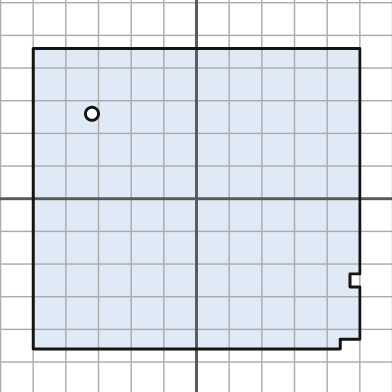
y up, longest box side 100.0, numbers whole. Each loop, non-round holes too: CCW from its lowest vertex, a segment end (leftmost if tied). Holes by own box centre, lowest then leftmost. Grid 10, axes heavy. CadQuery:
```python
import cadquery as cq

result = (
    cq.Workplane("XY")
    .moveTo(-50.0, -46.0)
    .lineTo(44.0, -46.0)
    .lineTo(44.0, -43.0)
    .lineTo(50.0, -43.0)
    .lineTo(50.0, -27.0)
    .lineTo(47.0, -27.0)
    .lineTo(47.0, -23.0)
    .lineTo(50.0, -23.0)
    .lineTo(50.0, 46.0)
    .lineTo(-50.0, 46.0)
    .close()
    .moveTo(-32.0, 26.0)
    .circle(2.0)
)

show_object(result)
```